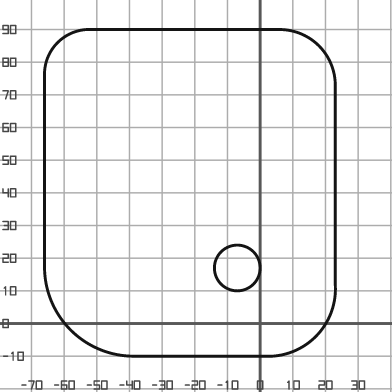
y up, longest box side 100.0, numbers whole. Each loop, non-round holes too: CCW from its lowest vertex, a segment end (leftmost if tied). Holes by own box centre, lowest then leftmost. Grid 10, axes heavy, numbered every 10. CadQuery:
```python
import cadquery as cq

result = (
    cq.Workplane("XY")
    .moveTo(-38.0, -10.0)
    .lineTo(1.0, -10.0)
    .threePointArc((17.0, -4.0), (23.0, 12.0))
    .lineTo(23.0, 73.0)
    .threePointArc((18.0, 85.0), (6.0, 90.0))
    .lineTo(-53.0, 90.0)
    .threePointArc((-62.0, 86.0), (-66.0, 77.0))
    .lineTo(-66.0, 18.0)
    .threePointArc((-58.0, -2.0), (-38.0, -10.0))
    .close()
    .moveTo(-7.0, 17.0)
    .circle(7.0)
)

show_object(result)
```